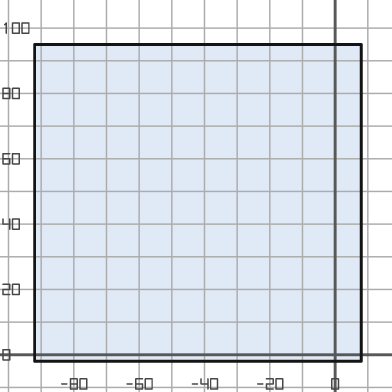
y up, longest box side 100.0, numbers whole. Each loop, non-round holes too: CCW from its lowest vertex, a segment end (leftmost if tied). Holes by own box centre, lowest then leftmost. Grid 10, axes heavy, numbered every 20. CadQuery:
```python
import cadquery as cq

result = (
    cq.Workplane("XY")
    .moveTo(-92.0, -2.0)
    .lineTo(8.0, -2.0)
    .lineTo(8.0, 95.0)
    .lineTo(-92.0, 95.0)
    .close()
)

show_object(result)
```